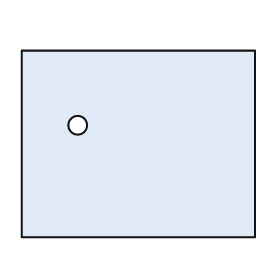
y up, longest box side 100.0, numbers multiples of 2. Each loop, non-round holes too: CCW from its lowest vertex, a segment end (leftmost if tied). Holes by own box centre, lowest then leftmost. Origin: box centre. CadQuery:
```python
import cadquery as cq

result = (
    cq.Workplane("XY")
    .moveTo(-50.0, -40.0)
    .lineTo(50.0, -40.0)
    .lineTo(50.0, 40.0)
    .lineTo(-50.0, 40.0)
    .close()
    .moveTo(-26.0, 8.0)
    .circle(4.0)
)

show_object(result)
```